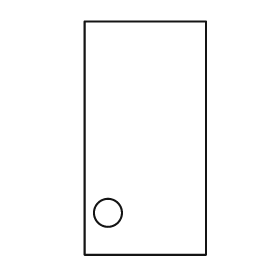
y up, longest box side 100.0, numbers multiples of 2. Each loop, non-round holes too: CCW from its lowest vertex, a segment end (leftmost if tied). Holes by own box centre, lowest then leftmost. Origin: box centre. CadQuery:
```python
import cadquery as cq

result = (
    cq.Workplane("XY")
    .moveTo(-26.0, -50.0)
    .lineTo(26.0, -50.0)
    .lineTo(26.0, 50.0)
    .lineTo(-26.0, 50.0)
    .close()
    .moveTo(-16.0, -32.0)
    .circle(6.0)
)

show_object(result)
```